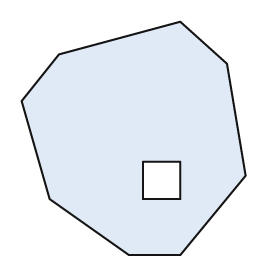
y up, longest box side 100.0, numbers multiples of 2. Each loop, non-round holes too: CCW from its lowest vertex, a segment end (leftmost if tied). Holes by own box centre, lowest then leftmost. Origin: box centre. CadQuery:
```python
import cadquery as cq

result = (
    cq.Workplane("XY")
    .moveTo(-2.0, -50.0)
    .lineTo(20.0, -50.0)
    .lineTo(48.0, -16.0)
    .lineTo(40.0, 32.0)
    .lineTo(20.0, 50.0)
    .lineTo(-32.0, 36.0)
    .lineTo(-48.0, 16.0)
    .lineTo(-36.0, -26.0)
    .close()
    .moveTo(4.0, -26.0)
    .lineTo(20.0, -26.0)
    .lineTo(20.0, -10.0)
    .lineTo(4.0, -10.0)
    .close()
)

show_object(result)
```